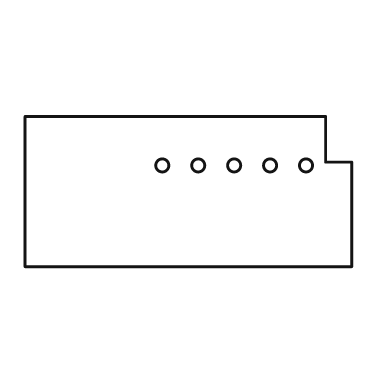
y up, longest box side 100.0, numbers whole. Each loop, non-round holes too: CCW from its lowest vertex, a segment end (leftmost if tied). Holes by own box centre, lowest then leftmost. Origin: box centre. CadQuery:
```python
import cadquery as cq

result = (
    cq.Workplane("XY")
    .moveTo(-50.0, -23.0)
    .lineTo(50.0, -23.0)
    .lineTo(50.0, 9.0)
    .lineTo(42.0, 9.0)
    .lineTo(42.0, 23.0)
    .lineTo(-50.0, 23.0)
    .close()
    .moveTo(-8.0, 8.0)
    .circle(2.0)
    .moveTo(3.0, 8.0)
    .circle(2.0)
    .moveTo(14.0, 8.0)
    .circle(2.0)
    .moveTo(25.0, 8.0)
    .circle(2.0)
    .moveTo(36.0, 8.0)
    .circle(2.0)
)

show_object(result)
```